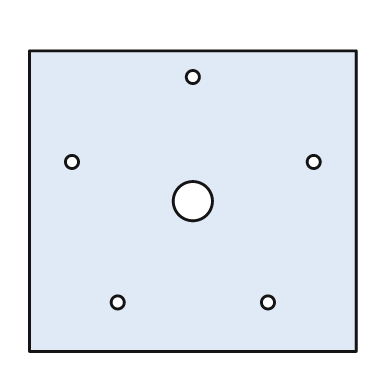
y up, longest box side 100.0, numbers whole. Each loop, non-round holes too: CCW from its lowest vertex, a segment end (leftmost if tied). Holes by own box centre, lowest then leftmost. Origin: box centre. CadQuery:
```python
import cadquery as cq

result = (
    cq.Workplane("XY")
    .moveTo(-50.0, -46.0)
    .lineTo(50.0, -46.0)
    .lineTo(50.0, 46.0)
    .lineTo(-50.0, 46.0)
    .close()
    .moveTo(-23.0, -31.0)
    .circle(2.0)
    .moveTo(23.0, -31.0)
    .circle(2.0)
    .moveTo(0.0, 0.0)
    .circle(6.0)
    .moveTo(-37.0, 12.0)
    .circle(2.0)
    .moveTo(37.0, 12.0)
    .circle(2.0)
    .moveTo(0.0, 38.0)
    .circle(2.0)
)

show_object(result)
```